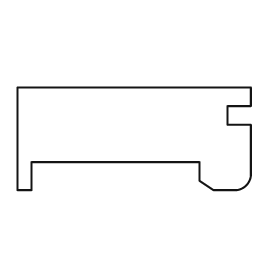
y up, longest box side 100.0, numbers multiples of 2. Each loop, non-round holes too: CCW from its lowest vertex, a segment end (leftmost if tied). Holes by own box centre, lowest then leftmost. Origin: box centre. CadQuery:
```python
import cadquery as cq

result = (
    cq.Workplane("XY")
    .moveTo(-50.0, -22.0)
    .lineTo(-44.0, -22.0)
    .lineTo(-44.0, -10.0)
    .lineTo(28.0, -10.0)
    .lineTo(28.0, -18.0)
    .lineTo(34.0, -22.0)
    .lineTo(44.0, -22.0)
    .threePointArc((48.0, -20.0), (50.0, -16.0))
    .lineTo(50.0, 6.0)
    .lineTo(40.0, 6.0)
    .lineTo(40.0, 14.0)
    .lineTo(50.0, 14.0)
    .lineTo(50.0, 22.0)
    .lineTo(-50.0, 22.0)
    .close()
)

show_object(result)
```